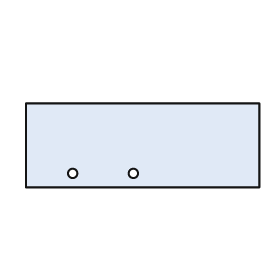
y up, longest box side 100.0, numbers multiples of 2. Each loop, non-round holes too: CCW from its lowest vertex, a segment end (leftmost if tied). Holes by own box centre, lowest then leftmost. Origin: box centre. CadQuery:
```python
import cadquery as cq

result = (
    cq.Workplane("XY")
    .moveTo(-50.0, -18.0)
    .lineTo(50.0, -18.0)
    .lineTo(50.0, 18.0)
    .lineTo(-50.0, 18.0)
    .close()
    .moveTo(-30.0, -12.0)
    .circle(2.0)
    .moveTo(-4.0, -12.0)
    .circle(2.0)
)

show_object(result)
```